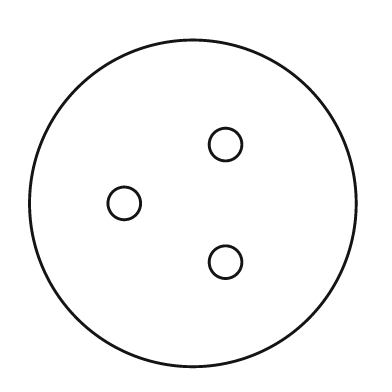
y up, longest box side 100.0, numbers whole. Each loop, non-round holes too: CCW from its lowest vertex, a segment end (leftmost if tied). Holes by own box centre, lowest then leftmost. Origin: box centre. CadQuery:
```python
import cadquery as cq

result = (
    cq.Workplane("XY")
    .moveTo(0.0, 0.0)
    .circle(50.0)
    .moveTo(10.0, -18.0)
    .circle(5.0)
    .moveTo(-21.0, 0.0)
    .circle(5.0)
    .moveTo(10.0, 18.0)
    .circle(5.0)
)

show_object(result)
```